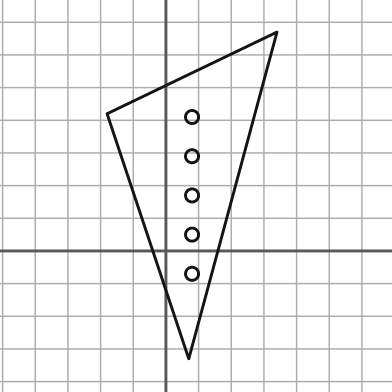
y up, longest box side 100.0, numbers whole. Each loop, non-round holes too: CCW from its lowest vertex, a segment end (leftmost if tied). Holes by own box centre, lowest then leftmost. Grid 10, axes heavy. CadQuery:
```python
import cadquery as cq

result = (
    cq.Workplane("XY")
    .moveTo(7.0, -33.0)
    .lineTo(34.0, 67.0)
    .lineTo(-18.0, 42.0)
    .close()
    .moveTo(8.0, -7.0)
    .circle(2.0)
    .moveTo(8.0, 5.0)
    .circle(2.0)
    .moveTo(8.0, 17.0)
    .circle(2.0)
    .moveTo(8.0, 29.0)
    .circle(2.0)
    .moveTo(8.0, 41.0)
    .circle(2.0)
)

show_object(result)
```